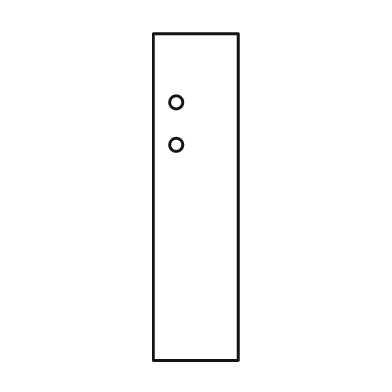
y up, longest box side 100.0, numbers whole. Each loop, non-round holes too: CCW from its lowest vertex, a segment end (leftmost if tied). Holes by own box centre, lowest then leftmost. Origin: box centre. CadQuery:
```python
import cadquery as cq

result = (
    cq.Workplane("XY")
    .moveTo(-13.0, -50.0)
    .lineTo(13.0, -50.0)
    .lineTo(13.0, 50.0)
    .lineTo(-13.0, 50.0)
    .close()
    .moveTo(-6.0, 16.0)
    .circle(2.0)
    .moveTo(-6.0, 29.0)
    .circle(2.0)
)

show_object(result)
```